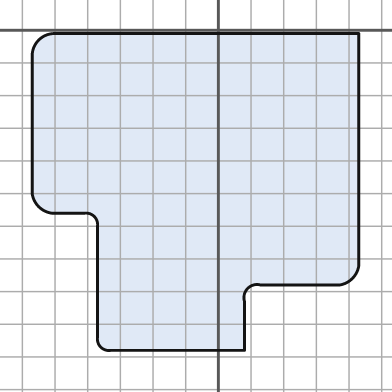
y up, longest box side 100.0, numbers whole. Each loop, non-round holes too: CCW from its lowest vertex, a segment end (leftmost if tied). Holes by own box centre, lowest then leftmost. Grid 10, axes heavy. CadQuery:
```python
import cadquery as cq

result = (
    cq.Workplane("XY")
    .moveTo(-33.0, -98.0)
    .lineTo(8.0, -98.0)
    .lineTo(8.0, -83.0)
    .threePointArc((9.0, -79.0), (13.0, -78.0))
    .lineTo(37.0, -78.0)
    .threePointArc((41.0, -76.0), (43.0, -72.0))
    .lineTo(43.0, -1.0)
    .lineTo(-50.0, -1.0)
    .threePointArc((-55.0, -3.0), (-57.0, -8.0))
    .lineTo(-57.0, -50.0)
    .threePointArc((-55.0, -54.0), (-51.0, -56.0))
    .lineTo(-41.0, -56.0)
    .threePointArc((-38.0, -57.0), (-37.0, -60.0))
    .lineTo(-37.0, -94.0)
    .threePointArc((-36.0, -97.0), (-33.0, -98.0))
    .close()
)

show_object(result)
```